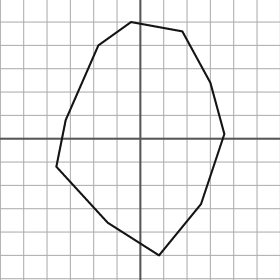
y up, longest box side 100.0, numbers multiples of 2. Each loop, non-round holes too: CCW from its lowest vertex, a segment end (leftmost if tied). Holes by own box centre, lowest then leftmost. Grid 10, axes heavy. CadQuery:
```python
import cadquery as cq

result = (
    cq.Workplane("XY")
    .moveTo(8.0, -50.0)
    .lineTo(26.0, -28.0)
    .lineTo(36.0, 2.0)
    .lineTo(30.0, 24.0)
    .lineTo(18.0, 46.0)
    .lineTo(-4.0, 50.0)
    .lineTo(-18.0, 40.0)
    .lineTo(-32.0, 8.0)
    .lineTo(-36.0, -12.0)
    .lineTo(-14.0, -36.0)
    .close()
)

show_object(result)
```